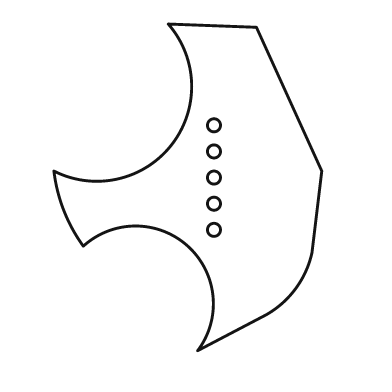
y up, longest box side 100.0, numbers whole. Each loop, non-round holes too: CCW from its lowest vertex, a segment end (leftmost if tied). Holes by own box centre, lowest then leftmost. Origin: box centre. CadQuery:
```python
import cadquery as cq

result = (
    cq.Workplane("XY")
    .moveTo(3.0, -50.0)
    .lineTo(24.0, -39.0)
    .threePointArc((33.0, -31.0), (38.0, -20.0))
    .lineTo(41.0, 5.0)
    .lineTo(21.0, 49.0)
    .lineTo(-6.0, 50.0)
    .threePointArc((-5.0, 13.0), (-41.0, 5.0))
    .threePointArc((-38.0, -7.0), (-32.0, -18.0))
    .threePointArc((0.0, -18.0), (3.0, -50.0))
    .close()
    .moveTo(8.0, -13.0)
    .circle(2.0)
    .moveTo(8.0, -5.0)
    .circle(2.0)
    .moveTo(8.0, 3.0)
    .circle(2.0)
    .moveTo(8.0, 11.0)
    .circle(2.0)
    .moveTo(8.0, 19.0)
    .circle(2.0)
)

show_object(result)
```